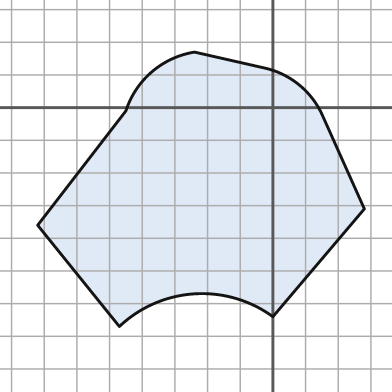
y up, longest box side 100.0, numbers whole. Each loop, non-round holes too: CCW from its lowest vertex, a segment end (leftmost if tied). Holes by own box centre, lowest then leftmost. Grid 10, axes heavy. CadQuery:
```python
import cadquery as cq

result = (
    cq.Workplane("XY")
    .moveTo(-47.0, -67.0)
    .threePointArc((-24.0, -57.0), (0.0, -64.0))
    .lineTo(28.0, -31.0)
    .lineTo(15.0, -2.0)
    .threePointArc((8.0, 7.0), (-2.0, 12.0))
    .lineTo(-24.0, 17.0)
    .threePointArc((-37.0, 11.0), (-45.0, -1.0))
    .lineTo(-72.0, -36.0)
    .close()
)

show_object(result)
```